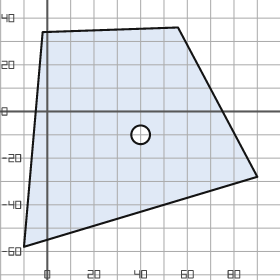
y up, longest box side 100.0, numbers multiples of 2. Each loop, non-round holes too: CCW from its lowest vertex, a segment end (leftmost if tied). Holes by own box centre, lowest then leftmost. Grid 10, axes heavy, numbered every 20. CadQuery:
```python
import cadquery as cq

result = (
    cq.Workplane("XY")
    .moveTo(-10.0, -58.0)
    .lineTo(90.0, -28.0)
    .lineTo(56.0, 36.0)
    .lineTo(-2.0, 34.0)
    .close()
    .moveTo(40.0, -10.0)
    .circle(4.0)
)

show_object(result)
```